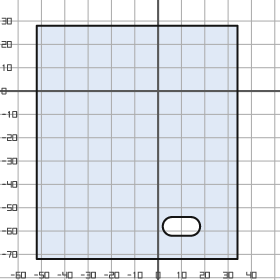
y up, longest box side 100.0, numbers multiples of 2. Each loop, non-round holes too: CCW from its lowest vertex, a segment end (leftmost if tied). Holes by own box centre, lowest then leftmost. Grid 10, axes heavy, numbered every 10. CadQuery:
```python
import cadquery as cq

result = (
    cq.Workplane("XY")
    .moveTo(-52.0, -72.0)
    .lineTo(34.0, -72.0)
    .lineTo(34.0, 28.0)
    .lineTo(-52.0, 28.0)
    .close()
    .moveTo(6.0, -62.0)
    .lineTo(14.0, -62.0)
    .threePointArc((18.0, -58.0), (14.0, -54.0))
    .lineTo(6.0, -54.0)
    .threePointArc((2.0, -58.0), (6.0, -62.0))
    .close()
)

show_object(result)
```